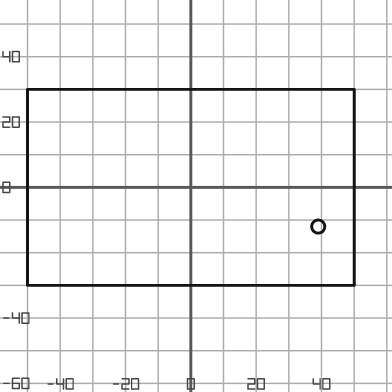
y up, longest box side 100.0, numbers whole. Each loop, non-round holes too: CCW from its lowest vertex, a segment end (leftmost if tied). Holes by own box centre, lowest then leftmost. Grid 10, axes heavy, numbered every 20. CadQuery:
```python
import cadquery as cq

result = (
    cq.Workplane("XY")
    .moveTo(-50.0, -30.0)
    .lineTo(50.0, -30.0)
    .lineTo(50.0, 30.0)
    .lineTo(-50.0, 30.0)
    .close()
    .moveTo(39.0, -12.0)
    .circle(2.0)
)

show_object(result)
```